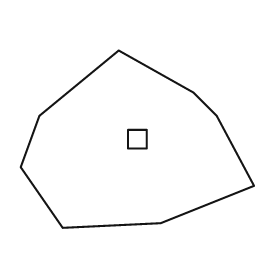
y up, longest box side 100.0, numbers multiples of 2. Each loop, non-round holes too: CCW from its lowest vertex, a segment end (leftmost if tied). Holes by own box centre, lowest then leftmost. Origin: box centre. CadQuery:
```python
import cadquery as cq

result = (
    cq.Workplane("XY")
    .moveTo(-32.0, -38.0)
    .lineTo(10.0, -36.0)
    .lineTo(50.0, -20.0)
    .lineTo(34.0, 10.0)
    .lineTo(24.0, 20.0)
    .lineTo(-8.0, 38.0)
    .lineTo(-42.0, 10.0)
    .lineTo(-50.0, -12.0)
    .close()
    .moveTo(-4.0, -4.0)
    .lineTo(4.0, -4.0)
    .lineTo(4.0, 4.0)
    .lineTo(-4.0, 4.0)
    .close()
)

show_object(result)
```